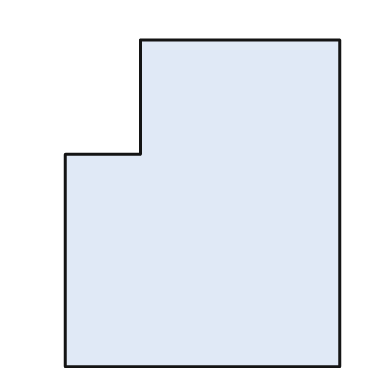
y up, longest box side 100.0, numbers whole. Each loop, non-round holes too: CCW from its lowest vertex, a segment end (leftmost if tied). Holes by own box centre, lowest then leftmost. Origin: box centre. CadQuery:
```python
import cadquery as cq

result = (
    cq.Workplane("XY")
    .moveTo(-42.0, -50.0)
    .lineTo(42.0, -50.0)
    .lineTo(42.0, 50.0)
    .lineTo(-19.0, 50.0)
    .lineTo(-19.0, 15.0)
    .lineTo(-42.0, 15.0)
    .close()
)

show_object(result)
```